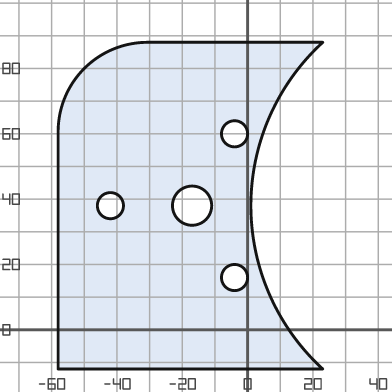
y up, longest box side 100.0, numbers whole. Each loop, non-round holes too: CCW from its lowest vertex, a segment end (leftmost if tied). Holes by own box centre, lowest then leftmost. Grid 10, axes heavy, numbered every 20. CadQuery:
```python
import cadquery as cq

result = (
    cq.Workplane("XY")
    .moveTo(-58.0, -12.0)
    .lineTo(23.0, -12.0)
    .threePointArc((1.0, 38.0), (23.0, 88.0))
    .lineTo(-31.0, 88.0)
    .threePointArc((-50.0, 80.0), (-58.0, 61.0))
    .close()
    .moveTo(-4.0, 16.0)
    .circle(4.0)
    .moveTo(-42.0, 38.0)
    .circle(4.0)
    .moveTo(-17.0, 38.0)
    .circle(6.0)
    .moveTo(-4.0, 60.0)
    .circle(4.0)
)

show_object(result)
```